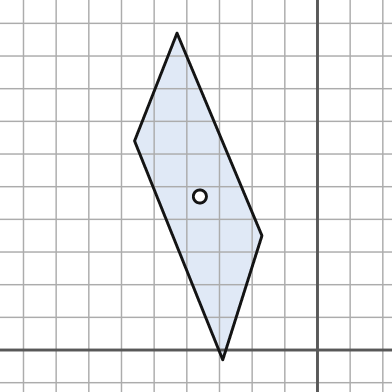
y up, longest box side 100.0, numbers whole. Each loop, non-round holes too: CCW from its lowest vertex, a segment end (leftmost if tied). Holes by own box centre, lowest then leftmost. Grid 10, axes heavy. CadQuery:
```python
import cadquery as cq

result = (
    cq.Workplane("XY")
    .moveTo(-29.0, -3.0)
    .lineTo(-17.0, 35.0)
    .lineTo(-43.0, 97.0)
    .lineTo(-56.0, 64.0)
    .close()
    .moveTo(-36.0, 47.0)
    .circle(2.0)
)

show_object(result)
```